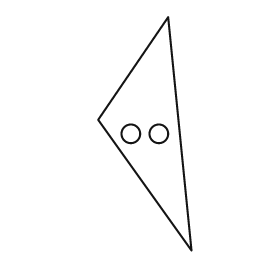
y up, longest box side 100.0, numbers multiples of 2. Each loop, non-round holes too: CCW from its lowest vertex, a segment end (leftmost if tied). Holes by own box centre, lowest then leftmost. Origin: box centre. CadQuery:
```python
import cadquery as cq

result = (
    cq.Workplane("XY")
    .moveTo(20.0, -50.0)
    .lineTo(10.0, 50.0)
    .lineTo(-20.0, 6.0)
    .close()
    .moveTo(-6.0, 0.0)
    .circle(4.0)
    .moveTo(6.0, 0.0)
    .circle(4.0)
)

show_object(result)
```